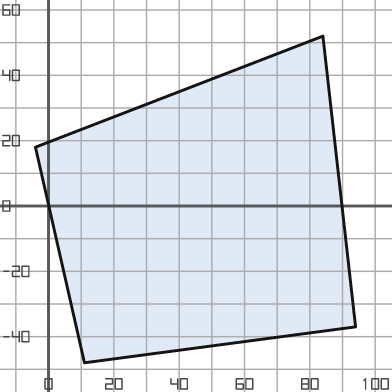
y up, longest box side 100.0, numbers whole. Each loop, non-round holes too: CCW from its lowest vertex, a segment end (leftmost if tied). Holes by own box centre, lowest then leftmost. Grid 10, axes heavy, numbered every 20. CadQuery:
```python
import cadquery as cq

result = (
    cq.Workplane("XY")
    .moveTo(11.0, -48.0)
    .lineTo(94.0, -37.0)
    .lineTo(84.0, 52.0)
    .lineTo(-4.0, 18.0)
    .close()
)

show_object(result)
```